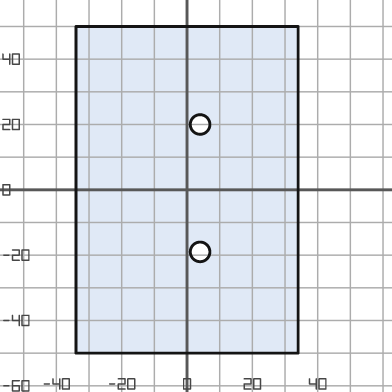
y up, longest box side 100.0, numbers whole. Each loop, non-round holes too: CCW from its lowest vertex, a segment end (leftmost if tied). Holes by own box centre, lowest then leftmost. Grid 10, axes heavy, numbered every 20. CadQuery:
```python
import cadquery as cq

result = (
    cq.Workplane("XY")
    .moveTo(-34.0, -50.0)
    .lineTo(34.0, -50.0)
    .lineTo(34.0, 50.0)
    .lineTo(-34.0, 50.0)
    .close()
    .moveTo(4.0, -19.0)
    .circle(3.0)
    .moveTo(4.0, 20.0)
    .circle(3.0)
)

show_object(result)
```